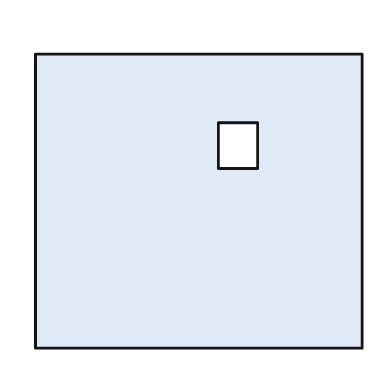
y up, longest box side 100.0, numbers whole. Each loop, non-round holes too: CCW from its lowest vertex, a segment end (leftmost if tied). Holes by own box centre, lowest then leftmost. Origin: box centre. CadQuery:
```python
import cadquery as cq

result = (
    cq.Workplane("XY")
    .moveTo(-50.0, -45.0)
    .lineTo(50.0, -45.0)
    .lineTo(50.0, 45.0)
    .lineTo(-50.0, 45.0)
    .close()
    .moveTo(6.0, 10.0)
    .lineTo(18.0, 10.0)
    .lineTo(18.0, 24.0)
    .lineTo(6.0, 24.0)
    .close()
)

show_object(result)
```